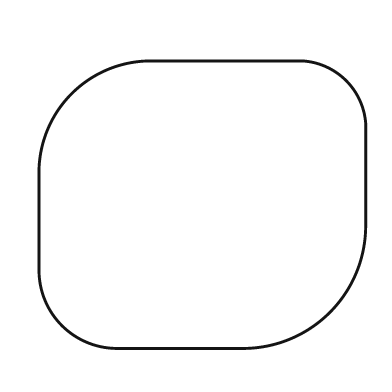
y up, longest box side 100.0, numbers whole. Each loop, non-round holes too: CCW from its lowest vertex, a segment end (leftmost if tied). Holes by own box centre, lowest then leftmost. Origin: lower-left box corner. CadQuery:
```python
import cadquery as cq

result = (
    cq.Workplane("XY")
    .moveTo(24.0, 0.0)
    .lineTo(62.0, 0.0)
    .threePointArc((89.0, 11.0), (100.0, 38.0))
    .lineTo(100.0, 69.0)
    .threePointArc((94.0, 82.0), (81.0, 88.0))
    .lineTo(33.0, 88.0)
    .threePointArc((10.0, 78.0), (0.0, 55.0))
    .lineTo(0.0, 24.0)
    .threePointArc((7.0, 7.0), (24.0, 0.0))
    .close()
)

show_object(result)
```